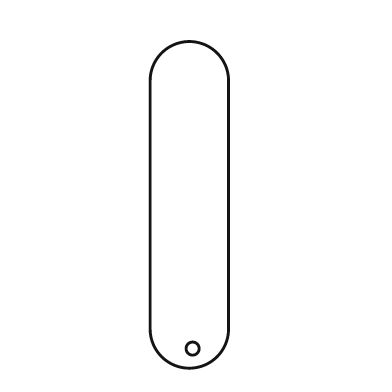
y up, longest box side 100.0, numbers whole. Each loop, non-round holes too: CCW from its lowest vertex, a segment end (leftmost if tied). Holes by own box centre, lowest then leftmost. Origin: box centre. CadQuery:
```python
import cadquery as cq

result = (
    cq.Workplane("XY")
    .moveTo(-12.0, -38.0)
    .threePointArc((0.0, -50.0), (12.0, -38.0))
    .lineTo(12.0, 38.0)
    .threePointArc((0.0, 50.0), (-12.0, 38.0))
    .close()
    .moveTo(1.0, -44.0)
    .circle(2.0)
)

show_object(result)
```